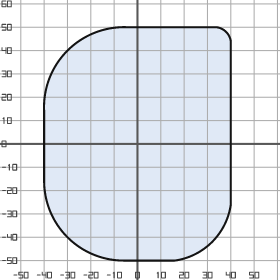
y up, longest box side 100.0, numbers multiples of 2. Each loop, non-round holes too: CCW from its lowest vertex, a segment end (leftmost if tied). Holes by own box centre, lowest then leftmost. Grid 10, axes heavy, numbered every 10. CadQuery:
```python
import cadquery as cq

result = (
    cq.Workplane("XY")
    .moveTo(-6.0, -50.0)
    .lineTo(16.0, -50.0)
    .threePointArc((32.0, -42.0), (40.0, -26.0))
    .lineTo(40.0, 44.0)
    .threePointArc((38.0, 48.0), (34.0, 50.0))
    .lineTo(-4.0, 50.0)
    .threePointArc((-30.0, 40.0), (-40.0, 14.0))
    .lineTo(-40.0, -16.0)
    .threePointArc((-30.0, -40.0), (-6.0, -50.0))
    .close()
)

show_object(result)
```